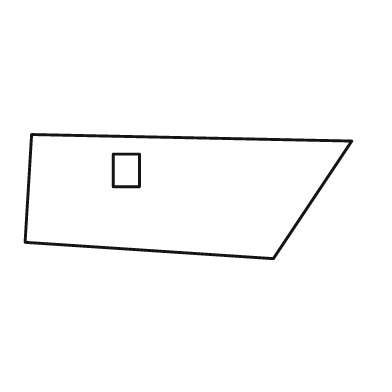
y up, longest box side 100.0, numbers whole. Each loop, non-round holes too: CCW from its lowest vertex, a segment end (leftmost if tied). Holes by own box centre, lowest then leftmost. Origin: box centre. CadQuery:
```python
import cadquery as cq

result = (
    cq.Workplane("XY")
    .moveTo(26.0, -19.0)
    .lineTo(50.0, 17.0)
    .lineTo(-48.0, 19.0)
    .lineTo(-50.0, -14.0)
    .close()
    .moveTo(-23.0, 3.0)
    .lineTo(-15.0, 3.0)
    .lineTo(-15.0, 13.0)
    .lineTo(-23.0, 13.0)
    .close()
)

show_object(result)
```